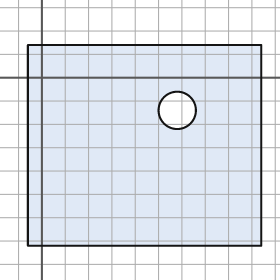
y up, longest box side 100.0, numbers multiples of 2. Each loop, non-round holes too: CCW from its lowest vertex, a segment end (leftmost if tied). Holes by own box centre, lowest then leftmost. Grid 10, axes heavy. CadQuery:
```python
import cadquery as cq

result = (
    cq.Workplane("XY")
    .moveTo(-6.0, -72.0)
    .lineTo(94.0, -72.0)
    .lineTo(94.0, 14.0)
    .lineTo(-6.0, 14.0)
    .close()
    .moveTo(58.0, -14.0)
    .circle(8.0)
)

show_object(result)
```